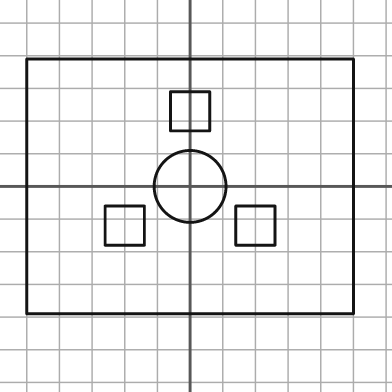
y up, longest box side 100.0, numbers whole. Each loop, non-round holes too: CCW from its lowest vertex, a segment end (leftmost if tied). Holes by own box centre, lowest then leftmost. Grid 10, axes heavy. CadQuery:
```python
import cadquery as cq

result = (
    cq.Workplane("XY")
    .moveTo(-50.0, -39.0)
    .lineTo(50.0, -39.0)
    .lineTo(50.0, 39.0)
    .lineTo(-50.0, 39.0)
    .close()
    .moveTo(-26.0, -18.0)
    .lineTo(-14.0, -18.0)
    .lineTo(-14.0, -6.0)
    .lineTo(-26.0, -6.0)
    .close()
    .moveTo(14.0, -18.0)
    .lineTo(26.0, -18.0)
    .lineTo(26.0, -6.0)
    .lineTo(14.0, -6.0)
    .close()
    .moveTo(0.0, 0.0)
    .circle(11.0)
    .moveTo(-6.0, 17.0)
    .lineTo(6.0, 17.0)
    .lineTo(6.0, 29.0)
    .lineTo(-6.0, 29.0)
    .close()
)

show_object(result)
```